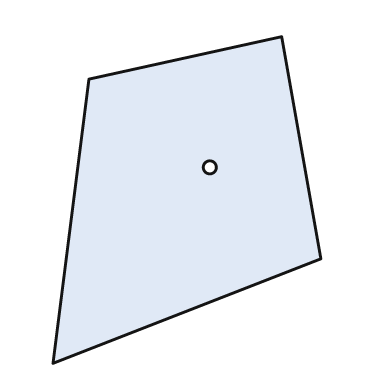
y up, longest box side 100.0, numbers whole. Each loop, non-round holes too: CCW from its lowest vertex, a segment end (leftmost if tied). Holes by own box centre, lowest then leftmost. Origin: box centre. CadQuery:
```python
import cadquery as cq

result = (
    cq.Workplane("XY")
    .moveTo(-41.0, -50.0)
    .lineTo(41.0, -18.0)
    .lineTo(29.0, 50.0)
    .lineTo(-30.0, 37.0)
    .close()
    .moveTo(7.0, 10.0)
    .circle(2.0)
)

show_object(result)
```